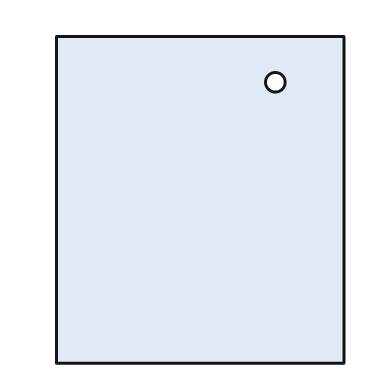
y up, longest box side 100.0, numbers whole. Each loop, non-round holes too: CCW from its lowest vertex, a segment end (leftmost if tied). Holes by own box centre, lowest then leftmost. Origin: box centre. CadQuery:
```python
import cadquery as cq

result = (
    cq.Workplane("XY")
    .moveTo(-44.0, -50.0)
    .lineTo(44.0, -50.0)
    .lineTo(44.0, 50.0)
    .lineTo(-44.0, 50.0)
    .close()
    .moveTo(23.0, 36.0)
    .circle(3.0)
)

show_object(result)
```